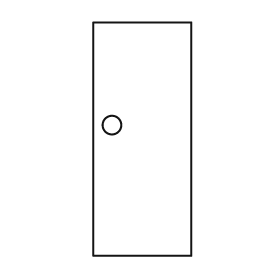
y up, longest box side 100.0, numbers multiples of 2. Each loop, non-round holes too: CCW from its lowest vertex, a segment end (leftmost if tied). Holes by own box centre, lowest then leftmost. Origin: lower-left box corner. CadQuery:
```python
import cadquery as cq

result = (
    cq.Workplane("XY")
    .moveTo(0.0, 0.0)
    .lineTo(42.0, 0.0)
    .lineTo(42.0, 100.0)
    .lineTo(0.0, 100.0)
    .close()
    .moveTo(8.0, 56.0)
    .circle(4.0)
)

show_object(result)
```